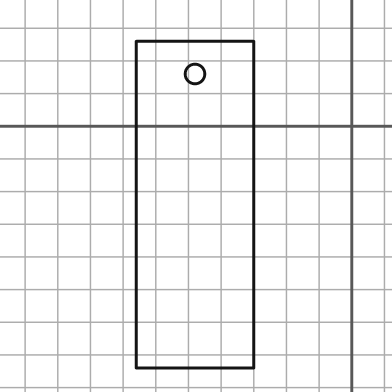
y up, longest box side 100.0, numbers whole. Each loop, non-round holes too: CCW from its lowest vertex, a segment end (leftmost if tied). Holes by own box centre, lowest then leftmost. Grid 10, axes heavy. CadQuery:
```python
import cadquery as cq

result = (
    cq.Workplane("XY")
    .moveTo(-66.0, -74.0)
    .lineTo(-30.0, -74.0)
    .lineTo(-30.0, 26.0)
    .lineTo(-66.0, 26.0)
    .close()
    .moveTo(-48.0, 16.0)
    .circle(3.0)
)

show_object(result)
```